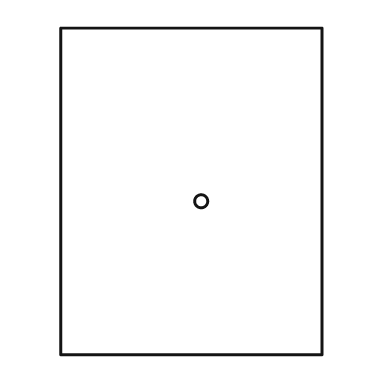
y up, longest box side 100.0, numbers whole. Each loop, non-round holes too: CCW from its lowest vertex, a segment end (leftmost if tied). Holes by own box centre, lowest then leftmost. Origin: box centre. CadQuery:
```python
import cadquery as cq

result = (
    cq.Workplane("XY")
    .moveTo(-40.0, -50.0)
    .lineTo(40.0, -50.0)
    .lineTo(40.0, 50.0)
    .lineTo(-40.0, 50.0)
    .close()
    .moveTo(3.0, -3.0)
    .circle(2.0)
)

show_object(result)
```